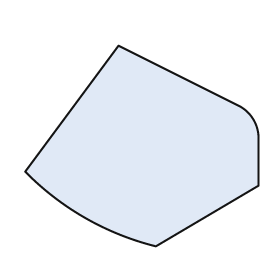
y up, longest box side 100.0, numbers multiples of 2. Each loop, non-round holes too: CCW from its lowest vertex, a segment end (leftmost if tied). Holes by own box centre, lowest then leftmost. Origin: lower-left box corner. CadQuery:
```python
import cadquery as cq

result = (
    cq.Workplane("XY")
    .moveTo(56.0, 0.0)
    .lineTo(100.0, 26.0)
    .lineTo(100.0, 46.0)
    .threePointArc((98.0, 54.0), (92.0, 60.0))
    .lineTo(40.0, 86.0)
    .lineTo(0.0, 32.0)
    .threePointArc((26.0, 12.0), (56.0, 0.0))
    .close()
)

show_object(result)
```